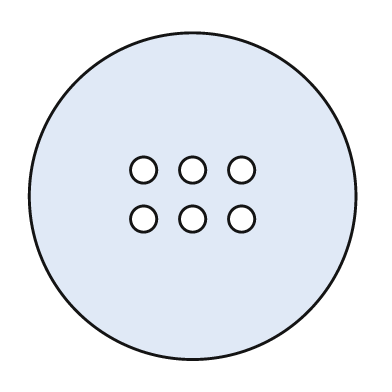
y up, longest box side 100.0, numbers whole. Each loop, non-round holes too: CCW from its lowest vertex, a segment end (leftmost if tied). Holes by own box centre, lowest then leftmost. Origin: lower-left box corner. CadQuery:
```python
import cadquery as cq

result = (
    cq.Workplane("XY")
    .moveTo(50.0, 50.0)
    .circle(50.0)
    .moveTo(35.0, 43.0)
    .circle(4.0)
    .moveTo(50.0, 43.0)
    .circle(4.0)
    .moveTo(65.0, 43.0)
    .circle(4.0)
    .moveTo(35.0, 58.0)
    .circle(4.0)
    .moveTo(50.0, 58.0)
    .circle(4.0)
    .moveTo(65.0, 58.0)
    .circle(4.0)
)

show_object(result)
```